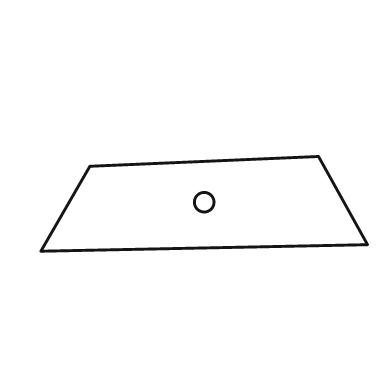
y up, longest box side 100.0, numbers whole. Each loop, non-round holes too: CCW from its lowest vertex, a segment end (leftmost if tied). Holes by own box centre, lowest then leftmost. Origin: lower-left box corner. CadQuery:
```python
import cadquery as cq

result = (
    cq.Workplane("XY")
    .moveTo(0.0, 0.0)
    .lineTo(100.0, 2.0)
    .lineTo(85.0, 29.0)
    .lineTo(15.0, 26.0)
    .close()
    .moveTo(50.0, 15.0)
    .circle(3.0)
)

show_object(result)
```